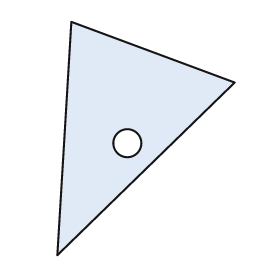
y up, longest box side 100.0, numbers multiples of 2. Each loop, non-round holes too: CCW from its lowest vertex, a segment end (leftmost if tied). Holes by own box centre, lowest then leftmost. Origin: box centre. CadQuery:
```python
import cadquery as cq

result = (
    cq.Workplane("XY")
    .moveTo(-38.0, -50.0)
    .lineTo(38.0, 24.0)
    .lineTo(-32.0, 50.0)
    .close()
    .moveTo(-8.0, -2.0)
    .circle(6.0)
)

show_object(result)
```